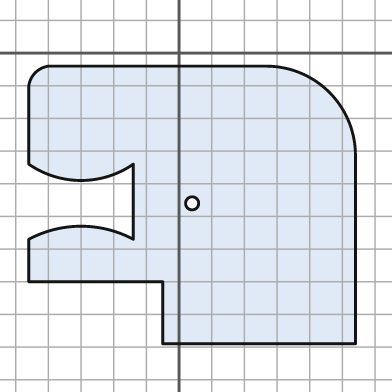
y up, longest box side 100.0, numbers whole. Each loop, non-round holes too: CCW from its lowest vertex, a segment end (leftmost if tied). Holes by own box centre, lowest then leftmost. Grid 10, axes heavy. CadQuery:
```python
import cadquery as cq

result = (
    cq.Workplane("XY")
    .moveTo(-5.0, -89.0)
    .lineTo(54.0, -89.0)
    .lineTo(54.0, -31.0)
    .threePointArc((46.0, -12.0), (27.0, -4.0))
    .lineTo(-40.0, -4.0)
    .threePointArc((-44.0, -6.0), (-46.0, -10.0))
    .lineTo(-46.0, -34.0)
    .threePointArc((-30.0, -39.0), (-14.0, -34.0))
    .lineTo(-14.0, -57.0)
    .threePointArc((-30.0, -53.0), (-46.0, -57.0))
    .lineTo(-46.0, -70.0)
    .lineTo(-5.0, -70.0)
    .close()
    .moveTo(4.0, -46.0)
    .circle(2.0)
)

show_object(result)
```